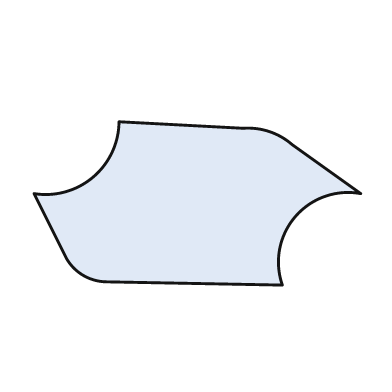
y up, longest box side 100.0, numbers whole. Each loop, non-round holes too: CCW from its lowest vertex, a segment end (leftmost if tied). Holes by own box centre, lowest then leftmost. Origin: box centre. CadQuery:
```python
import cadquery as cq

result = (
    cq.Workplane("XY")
    .moveTo(26.0, -25.0)
    .threePointArc((30.0, -4.0), (50.0, 3.0))
    .lineTo(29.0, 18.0)
    .threePointArc((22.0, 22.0), (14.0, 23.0))
    .lineTo(-24.0, 25.0)
    .threePointArc((-32.0, 8.0), (-50.0, 3.0))
    .lineTo(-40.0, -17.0)
    .threePointArc((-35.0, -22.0), (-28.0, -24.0))
    .close()
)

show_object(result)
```